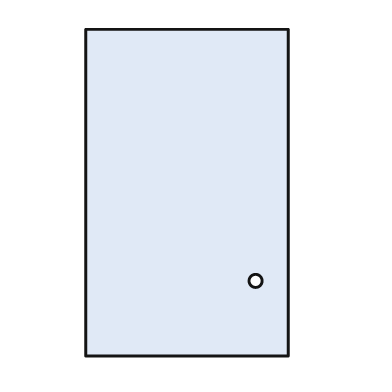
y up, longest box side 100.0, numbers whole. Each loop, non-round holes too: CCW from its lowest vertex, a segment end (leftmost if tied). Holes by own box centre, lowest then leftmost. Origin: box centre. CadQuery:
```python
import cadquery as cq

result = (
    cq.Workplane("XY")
    .moveTo(-31.0, -50.0)
    .lineTo(31.0, -50.0)
    .lineTo(31.0, 50.0)
    .lineTo(-31.0, 50.0)
    .close()
    .moveTo(21.0, -27.0)
    .circle(2.0)
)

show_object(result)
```